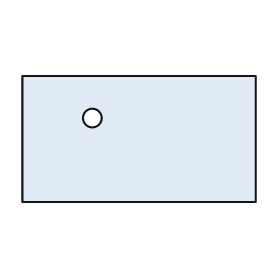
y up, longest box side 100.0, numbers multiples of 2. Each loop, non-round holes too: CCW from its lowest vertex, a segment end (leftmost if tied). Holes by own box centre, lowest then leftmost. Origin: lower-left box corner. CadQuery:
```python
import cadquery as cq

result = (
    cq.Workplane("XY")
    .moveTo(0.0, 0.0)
    .lineTo(100.0, 0.0)
    .lineTo(100.0, 54.0)
    .lineTo(0.0, 54.0)
    .close()
    .moveTo(30.0, 36.0)
    .circle(4.0)
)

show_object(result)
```